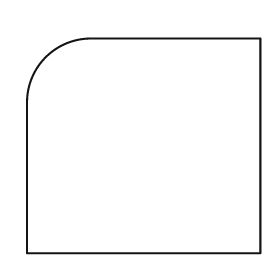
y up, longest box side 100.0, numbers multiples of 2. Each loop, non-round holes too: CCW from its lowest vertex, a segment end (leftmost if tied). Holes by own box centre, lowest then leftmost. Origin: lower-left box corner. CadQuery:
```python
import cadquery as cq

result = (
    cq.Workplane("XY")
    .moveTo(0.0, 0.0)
    .lineTo(100.0, 0.0)
    .lineTo(100.0, 92.0)
    .lineTo(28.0, 92.0)
    .threePointArc((8.0, 84.0), (0.0, 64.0))
    .close()
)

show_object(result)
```